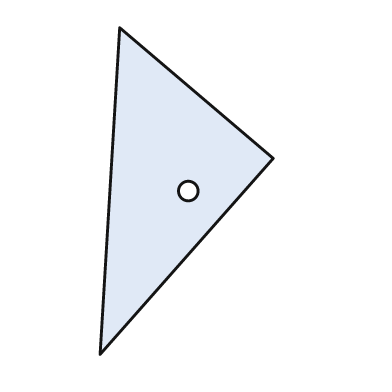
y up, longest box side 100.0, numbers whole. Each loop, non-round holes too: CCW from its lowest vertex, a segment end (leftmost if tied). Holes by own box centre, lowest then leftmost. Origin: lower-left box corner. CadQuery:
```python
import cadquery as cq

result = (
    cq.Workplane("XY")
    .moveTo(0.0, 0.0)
    .lineTo(53.0, 60.0)
    .lineTo(6.0, 100.0)
    .close()
    .moveTo(27.0, 50.0)
    .circle(3.0)
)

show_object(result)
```